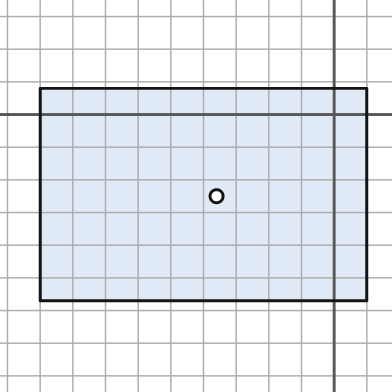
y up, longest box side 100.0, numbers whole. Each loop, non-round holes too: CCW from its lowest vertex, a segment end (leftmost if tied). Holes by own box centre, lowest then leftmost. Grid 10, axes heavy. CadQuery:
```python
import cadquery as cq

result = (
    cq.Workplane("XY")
    .moveTo(-90.0, -57.0)
    .lineTo(10.0, -57.0)
    .lineTo(10.0, 8.0)
    .lineTo(-90.0, 8.0)
    .close()
    .moveTo(-36.0, -25.0)
    .circle(2.0)
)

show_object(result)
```